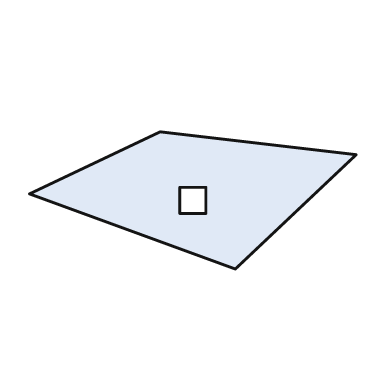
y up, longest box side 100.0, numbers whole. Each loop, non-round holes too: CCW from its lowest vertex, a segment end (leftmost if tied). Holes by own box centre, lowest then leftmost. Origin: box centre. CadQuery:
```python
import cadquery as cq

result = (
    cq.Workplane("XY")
    .moveTo(13.0, -21.0)
    .lineTo(50.0, 14.0)
    .lineTo(-10.0, 21.0)
    .lineTo(-50.0, 2.0)
    .close()
    .moveTo(-4.0, -4.0)
    .lineTo(4.0, -4.0)
    .lineTo(4.0, 4.0)
    .lineTo(-4.0, 4.0)
    .close()
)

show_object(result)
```